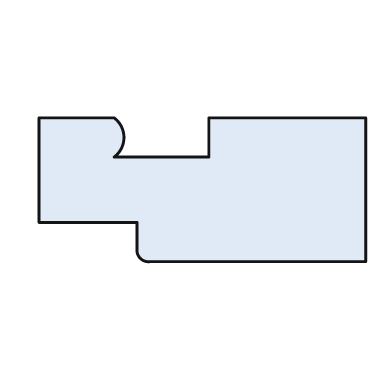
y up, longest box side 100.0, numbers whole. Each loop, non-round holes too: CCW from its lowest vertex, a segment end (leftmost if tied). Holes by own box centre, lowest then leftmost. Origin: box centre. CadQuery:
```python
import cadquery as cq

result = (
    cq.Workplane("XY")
    .moveTo(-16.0, -22.0)
    .lineTo(50.0, -22.0)
    .lineTo(50.0, 22.0)
    .lineTo(2.0, 22.0)
    .lineTo(2.0, 10.0)
    .lineTo(-27.0, 10.0)
    .threePointArc((-24.0, 16.0), (-27.0, 22.0))
    .lineTo(-50.0, 22.0)
    .lineTo(-50.0, -10.0)
    .lineTo(-20.0, -10.0)
    .lineTo(-20.0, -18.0)
    .threePointArc((-19.0, -21.0), (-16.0, -22.0))
    .close()
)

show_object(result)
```